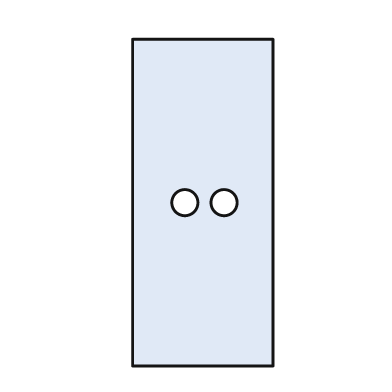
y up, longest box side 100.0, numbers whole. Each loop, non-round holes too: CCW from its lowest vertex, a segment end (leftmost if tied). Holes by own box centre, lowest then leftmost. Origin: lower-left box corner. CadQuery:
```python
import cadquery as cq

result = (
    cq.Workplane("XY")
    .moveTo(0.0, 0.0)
    .lineTo(43.0, 0.0)
    .lineTo(43.0, 100.0)
    .lineTo(0.0, 100.0)
    .close()
    .moveTo(16.0, 50.0)
    .circle(4.0)
    .moveTo(28.0, 50.0)
    .circle(4.0)
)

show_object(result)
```